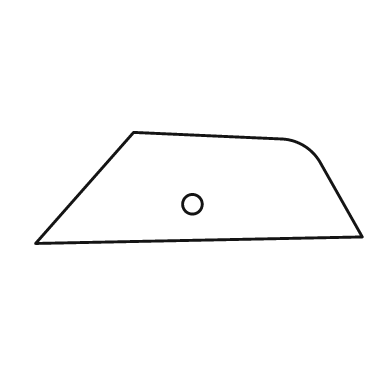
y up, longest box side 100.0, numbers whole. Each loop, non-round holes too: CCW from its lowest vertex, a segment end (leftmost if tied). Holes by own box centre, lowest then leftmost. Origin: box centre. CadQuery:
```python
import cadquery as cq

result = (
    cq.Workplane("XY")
    .moveTo(-50.0, -17.0)
    .lineTo(50.0, -15.0)
    .lineTo(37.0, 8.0)
    .threePointArc((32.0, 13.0), (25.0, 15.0))
    .lineTo(-20.0, 17.0)
    .close()
    .moveTo(-2.0, -5.0)
    .circle(3.0)
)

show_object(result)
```